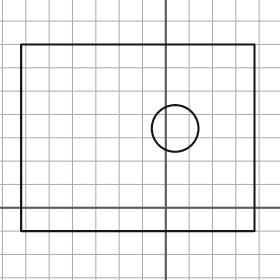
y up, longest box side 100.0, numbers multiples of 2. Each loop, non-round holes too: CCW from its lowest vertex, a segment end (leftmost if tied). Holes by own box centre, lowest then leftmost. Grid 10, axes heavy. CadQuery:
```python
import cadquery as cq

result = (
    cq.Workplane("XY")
    .moveTo(-62.0, -10.0)
    .lineTo(38.0, -10.0)
    .lineTo(38.0, 70.0)
    .lineTo(-62.0, 70.0)
    .close()
    .moveTo(4.0, 34.0)
    .circle(10.0)
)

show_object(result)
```